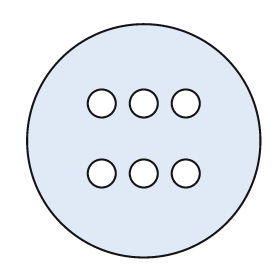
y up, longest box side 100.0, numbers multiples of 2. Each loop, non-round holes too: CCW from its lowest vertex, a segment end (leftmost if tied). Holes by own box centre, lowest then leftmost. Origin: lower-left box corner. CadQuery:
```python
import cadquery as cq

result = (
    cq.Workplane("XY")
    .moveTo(50.0, 50.0)
    .circle(50.0)
    .moveTo(32.0, 36.0)
    .circle(6.0)
    .moveTo(50.0, 36.0)
    .circle(6.0)
    .moveTo(68.0, 36.0)
    .circle(6.0)
    .moveTo(32.0, 66.0)
    .circle(6.0)
    .moveTo(50.0, 66.0)
    .circle(6.0)
    .moveTo(68.0, 66.0)
    .circle(6.0)
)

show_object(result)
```